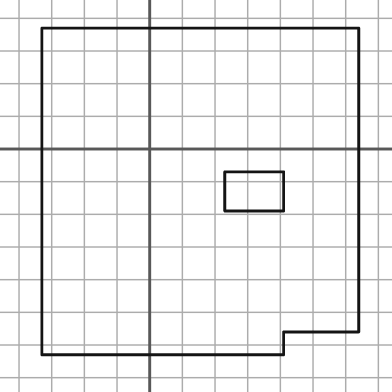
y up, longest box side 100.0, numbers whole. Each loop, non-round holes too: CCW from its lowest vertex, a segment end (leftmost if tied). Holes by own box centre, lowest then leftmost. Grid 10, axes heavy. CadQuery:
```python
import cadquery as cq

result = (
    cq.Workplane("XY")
    .moveTo(-33.0, -63.0)
    .lineTo(41.0, -63.0)
    .lineTo(41.0, -56.0)
    .lineTo(64.0, -56.0)
    .lineTo(64.0, 37.0)
    .lineTo(-33.0, 37.0)
    .close()
    .moveTo(23.0, -19.0)
    .lineTo(41.0, -19.0)
    .lineTo(41.0, -7.0)
    .lineTo(23.0, -7.0)
    .close()
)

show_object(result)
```